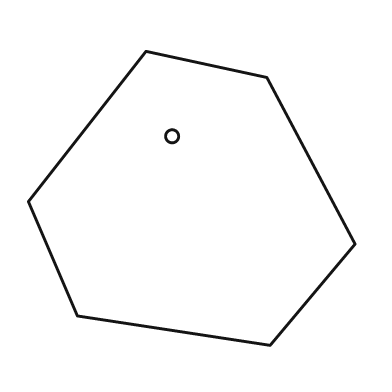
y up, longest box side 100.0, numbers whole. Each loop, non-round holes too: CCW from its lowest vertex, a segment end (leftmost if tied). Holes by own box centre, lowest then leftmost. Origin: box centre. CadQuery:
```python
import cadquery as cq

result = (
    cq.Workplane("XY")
    .moveTo(24.0, -45.0)
    .lineTo(50.0, -14.0)
    .lineTo(23.0, 37.0)
    .lineTo(-14.0, 45.0)
    .lineTo(-50.0, -1.0)
    .lineTo(-35.0, -36.0)
    .close()
    .moveTo(-6.0, 19.0)
    .circle(2.0)
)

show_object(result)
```